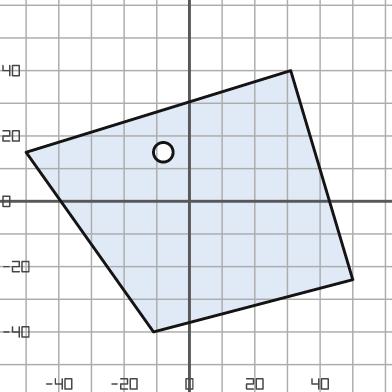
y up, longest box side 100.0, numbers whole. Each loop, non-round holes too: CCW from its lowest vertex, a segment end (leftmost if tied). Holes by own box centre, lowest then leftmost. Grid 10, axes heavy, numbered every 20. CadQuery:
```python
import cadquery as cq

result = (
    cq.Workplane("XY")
    .moveTo(-11.0, -40.0)
    .lineTo(50.0, -24.0)
    .lineTo(31.0, 40.0)
    .lineTo(-50.0, 15.0)
    .close()
    .moveTo(-8.0, 15.0)
    .circle(3.0)
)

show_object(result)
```